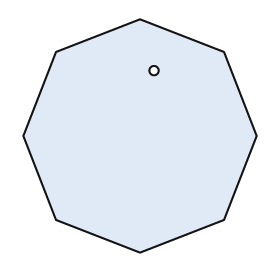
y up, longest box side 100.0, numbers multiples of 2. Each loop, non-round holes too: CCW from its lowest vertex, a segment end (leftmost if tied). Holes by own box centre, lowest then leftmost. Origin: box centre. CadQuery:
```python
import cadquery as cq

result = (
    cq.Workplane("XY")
    .moveTo(0.0, -50.0)
    .lineTo(36.0, -36.0)
    .lineTo(50.0, 0.0)
    .lineTo(36.0, 36.0)
    .lineTo(0.0, 50.0)
    .lineTo(-36.0, 36.0)
    .lineTo(-50.0, 0.0)
    .lineTo(-36.0, -36.0)
    .close()
    .moveTo(6.0, 28.0)
    .circle(2.0)
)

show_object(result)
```